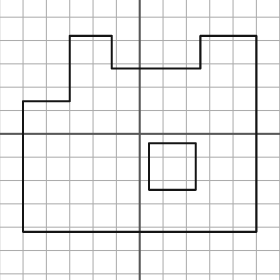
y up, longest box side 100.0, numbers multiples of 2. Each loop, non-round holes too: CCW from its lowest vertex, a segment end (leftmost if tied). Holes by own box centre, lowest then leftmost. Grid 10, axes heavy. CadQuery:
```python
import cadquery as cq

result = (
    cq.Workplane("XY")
    .moveTo(-50.0, -42.0)
    .lineTo(50.0, -42.0)
    .lineTo(50.0, 42.0)
    .lineTo(26.0, 42.0)
    .lineTo(26.0, 28.0)
    .lineTo(-12.0, 28.0)
    .lineTo(-12.0, 42.0)
    .lineTo(-30.0, 42.0)
    .lineTo(-30.0, 14.0)
    .lineTo(-50.0, 14.0)
    .close()
    .moveTo(4.0, -24.0)
    .lineTo(24.0, -24.0)
    .lineTo(24.0, -4.0)
    .lineTo(4.0, -4.0)
    .close()
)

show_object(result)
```